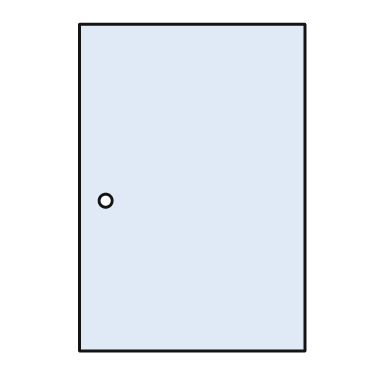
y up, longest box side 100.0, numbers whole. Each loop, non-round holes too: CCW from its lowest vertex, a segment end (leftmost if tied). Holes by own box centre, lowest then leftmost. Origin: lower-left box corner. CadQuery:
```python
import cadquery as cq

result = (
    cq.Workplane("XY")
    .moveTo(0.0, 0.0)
    .lineTo(69.0, 0.0)
    .lineTo(69.0, 100.0)
    .lineTo(0.0, 100.0)
    .close()
    .moveTo(8.0, 46.0)
    .circle(2.0)
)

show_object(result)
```